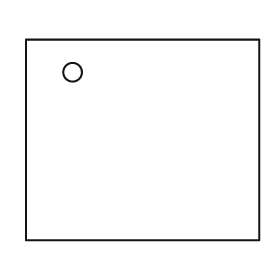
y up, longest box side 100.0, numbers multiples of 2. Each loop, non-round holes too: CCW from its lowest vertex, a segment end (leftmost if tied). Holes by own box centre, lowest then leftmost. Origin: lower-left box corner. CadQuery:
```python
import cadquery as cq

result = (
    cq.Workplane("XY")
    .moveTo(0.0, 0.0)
    .lineTo(100.0, 0.0)
    .lineTo(100.0, 86.0)
    .lineTo(0.0, 86.0)
    .close()
    .moveTo(20.0, 72.0)
    .circle(4.0)
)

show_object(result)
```